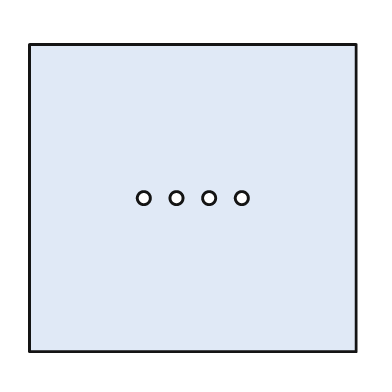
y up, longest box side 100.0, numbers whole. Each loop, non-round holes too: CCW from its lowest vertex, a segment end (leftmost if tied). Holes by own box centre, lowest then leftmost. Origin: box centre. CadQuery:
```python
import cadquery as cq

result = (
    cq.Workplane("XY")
    .moveTo(-50.0, -47.0)
    .lineTo(50.0, -47.0)
    .lineTo(50.0, 47.0)
    .lineTo(-50.0, 47.0)
    .close()
    .moveTo(-15.0, 0.0)
    .circle(2.0)
    .moveTo(-5.0, 0.0)
    .circle(2.0)
    .moveTo(5.0, 0.0)
    .circle(2.0)
    .moveTo(15.0, 0.0)
    .circle(2.0)
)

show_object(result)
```